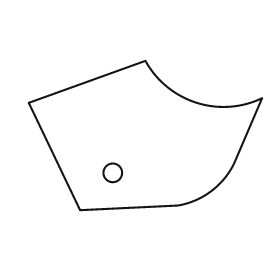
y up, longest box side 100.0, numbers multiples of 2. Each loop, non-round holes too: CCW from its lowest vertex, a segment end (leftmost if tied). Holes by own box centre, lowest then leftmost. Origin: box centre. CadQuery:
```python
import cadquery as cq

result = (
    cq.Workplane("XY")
    .moveTo(-28.0, -32.0)
    .lineTo(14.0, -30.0)
    .threePointArc((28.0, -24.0), (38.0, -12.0))
    .lineTo(50.0, 16.0)
    .threePointArc((22.0, 14.0), (0.0, 32.0))
    .lineTo(-50.0, 14.0)
    .close()
    .moveTo(-14.0, -16.0)
    .circle(4.0)
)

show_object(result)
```